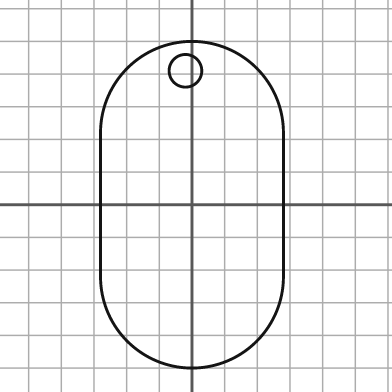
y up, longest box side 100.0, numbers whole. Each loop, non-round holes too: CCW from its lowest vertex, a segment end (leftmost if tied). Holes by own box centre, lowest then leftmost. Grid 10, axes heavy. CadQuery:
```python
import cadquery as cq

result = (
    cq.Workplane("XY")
    .moveTo(-28.0, -22.0)
    .threePointArc((0.0, -50.0), (28.0, -22.0))
    .lineTo(28.0, 22.0)
    .threePointArc((0.0, 50.0), (-28.0, 22.0))
    .close()
    .moveTo(-2.0, 41.0)
    .circle(5.0)
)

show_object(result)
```